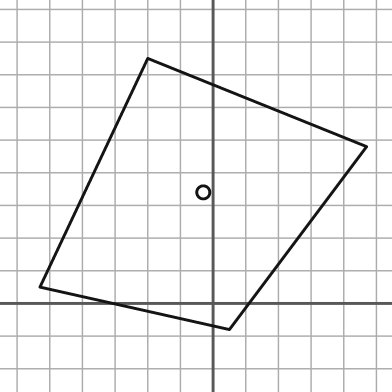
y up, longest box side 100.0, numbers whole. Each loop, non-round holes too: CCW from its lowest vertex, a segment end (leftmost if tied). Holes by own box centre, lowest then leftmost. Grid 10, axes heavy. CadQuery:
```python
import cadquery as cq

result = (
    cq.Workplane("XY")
    .moveTo(5.0, -8.0)
    .lineTo(47.0, 48.0)
    .lineTo(-20.0, 75.0)
    .lineTo(-53.0, 5.0)
    .close()
    .moveTo(-3.0, 34.0)
    .circle(2.0)
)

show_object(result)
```